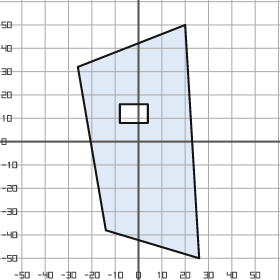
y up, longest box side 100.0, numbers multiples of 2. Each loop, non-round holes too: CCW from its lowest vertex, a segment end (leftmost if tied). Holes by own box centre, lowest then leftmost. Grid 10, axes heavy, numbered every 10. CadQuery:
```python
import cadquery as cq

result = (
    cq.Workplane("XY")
    .moveTo(26.0, -50.0)
    .lineTo(20.0, 50.0)
    .lineTo(-26.0, 32.0)
    .lineTo(-14.0, -38.0)
    .close()
    .moveTo(-8.0, 8.0)
    .lineTo(4.0, 8.0)
    .lineTo(4.0, 16.0)
    .lineTo(-8.0, 16.0)
    .close()
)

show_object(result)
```